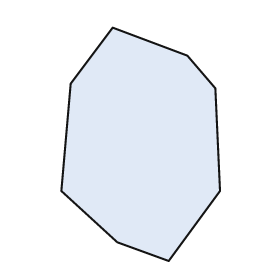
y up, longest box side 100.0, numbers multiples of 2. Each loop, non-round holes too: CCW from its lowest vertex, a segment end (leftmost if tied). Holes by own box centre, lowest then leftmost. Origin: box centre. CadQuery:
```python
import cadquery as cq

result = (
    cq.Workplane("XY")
    .moveTo(12.0, -50.0)
    .lineTo(34.0, -20.0)
    .lineTo(32.0, 24.0)
    .lineTo(20.0, 38.0)
    .lineTo(-12.0, 50.0)
    .lineTo(-30.0, 26.0)
    .lineTo(-34.0, -20.0)
    .lineTo(-10.0, -42.0)
    .close()
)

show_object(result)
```